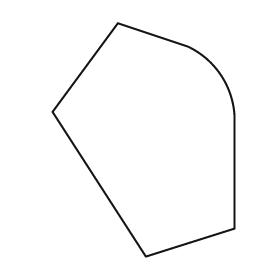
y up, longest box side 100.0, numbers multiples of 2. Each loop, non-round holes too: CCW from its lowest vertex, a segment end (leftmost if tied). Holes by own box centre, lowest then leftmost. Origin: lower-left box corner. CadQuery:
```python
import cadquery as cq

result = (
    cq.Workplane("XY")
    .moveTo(40.0, 0.0)
    .lineTo(78.0, 12.0)
    .lineTo(78.0, 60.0)
    .threePointArc((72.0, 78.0), (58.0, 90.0))
    .lineTo(28.0, 100.0)
    .lineTo(0.0, 62.0)
    .close()
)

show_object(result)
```